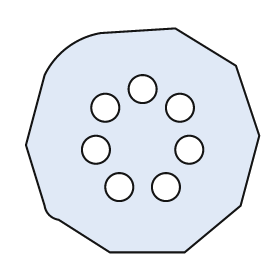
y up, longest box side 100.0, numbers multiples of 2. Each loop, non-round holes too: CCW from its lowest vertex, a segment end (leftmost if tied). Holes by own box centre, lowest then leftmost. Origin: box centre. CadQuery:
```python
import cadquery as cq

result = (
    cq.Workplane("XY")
    .moveTo(-14.0, -48.0)
    .lineTo(18.0, -48.0)
    .lineTo(42.0, -28.0)
    .lineTo(50.0, 2.0)
    .lineTo(40.0, 32.0)
    .lineTo(14.0, 48.0)
    .lineTo(-18.0, 46.0)
    .threePointArc((-32.0, 40.0), (-42.0, 28.0))
    .lineTo(-50.0, -2.0)
    .lineTo(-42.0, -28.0)
    .threePointArc((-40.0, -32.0), (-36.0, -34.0))
    .close()
    .moveTo(-10.0, -20.0)
    .circle(6.0)
    .moveTo(10.0, -20.0)
    .circle(6.0)
    .moveTo(-20.0, -4.0)
    .circle(6.0)
    .moveTo(20.0, -4.0)
    .circle(6.0)
    .moveTo(-16.0, 14.0)
    .circle(6.0)
    .moveTo(16.0, 14.0)
    .circle(6.0)
    .moveTo(0.0, 22.0)
    .circle(6.0)
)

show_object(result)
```